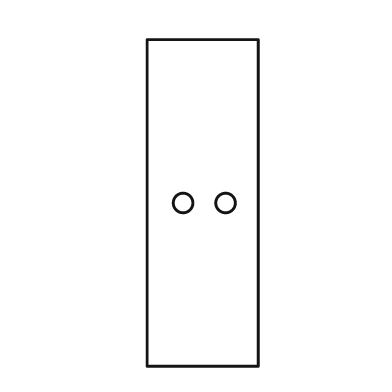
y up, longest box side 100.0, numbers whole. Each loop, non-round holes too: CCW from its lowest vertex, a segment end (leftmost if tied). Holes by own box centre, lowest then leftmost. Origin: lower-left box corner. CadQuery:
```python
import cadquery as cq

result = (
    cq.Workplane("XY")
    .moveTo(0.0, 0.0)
    .lineTo(34.0, 0.0)
    .lineTo(34.0, 100.0)
    .lineTo(0.0, 100.0)
    .close()
    .moveTo(11.0, 50.0)
    .circle(3.0)
    .moveTo(24.0, 50.0)
    .circle(3.0)
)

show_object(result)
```